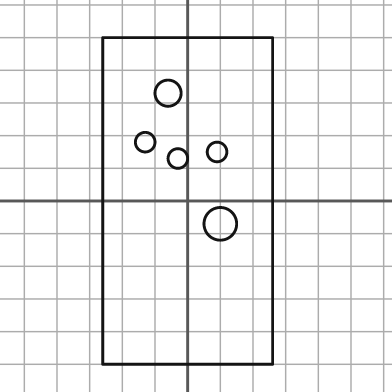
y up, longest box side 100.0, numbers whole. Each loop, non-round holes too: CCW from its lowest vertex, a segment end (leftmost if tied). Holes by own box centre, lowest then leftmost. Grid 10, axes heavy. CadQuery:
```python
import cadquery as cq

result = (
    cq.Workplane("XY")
    .moveTo(-26.0, -50.0)
    .lineTo(26.0, -50.0)
    .lineTo(26.0, 50.0)
    .lineTo(-26.0, 50.0)
    .close()
    .moveTo(10.0, -7.0)
    .circle(5.0)
    .moveTo(-3.0, 13.0)
    .circle(3.0)
    .moveTo(9.0, 15.0)
    .circle(3.0)
    .moveTo(-13.0, 18.0)
    .circle(3.0)
    .moveTo(-6.0, 33.0)
    .circle(4.0)
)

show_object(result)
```